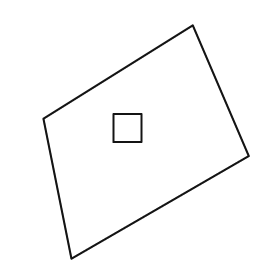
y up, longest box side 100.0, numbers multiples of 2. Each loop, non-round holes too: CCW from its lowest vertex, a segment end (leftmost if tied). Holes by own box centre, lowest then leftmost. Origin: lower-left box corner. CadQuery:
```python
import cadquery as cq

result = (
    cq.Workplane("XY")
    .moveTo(12.0, 0.0)
    .lineTo(88.0, 44.0)
    .lineTo(64.0, 100.0)
    .lineTo(0.0, 60.0)
    .close()
    .moveTo(30.0, 50.0)
    .lineTo(42.0, 50.0)
    .lineTo(42.0, 62.0)
    .lineTo(30.0, 62.0)
    .close()
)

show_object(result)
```